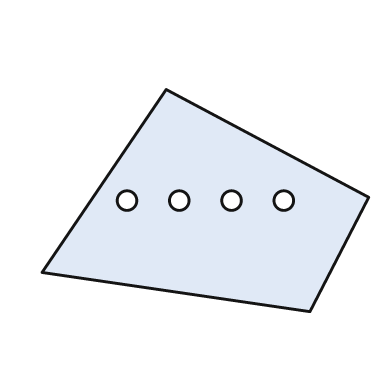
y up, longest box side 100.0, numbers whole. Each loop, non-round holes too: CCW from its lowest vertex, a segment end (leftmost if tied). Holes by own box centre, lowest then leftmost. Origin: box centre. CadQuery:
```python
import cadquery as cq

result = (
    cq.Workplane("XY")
    .moveTo(32.0, -34.0)
    .lineTo(50.0, 1.0)
    .lineTo(-12.0, 34.0)
    .lineTo(-50.0, -22.0)
    .close()
    .moveTo(-24.0, 0.0)
    .circle(3.0)
    .moveTo(-8.0, 0.0)
    .circle(3.0)
    .moveTo(8.0, 0.0)
    .circle(3.0)
    .moveTo(24.0, 0.0)
    .circle(3.0)
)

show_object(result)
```